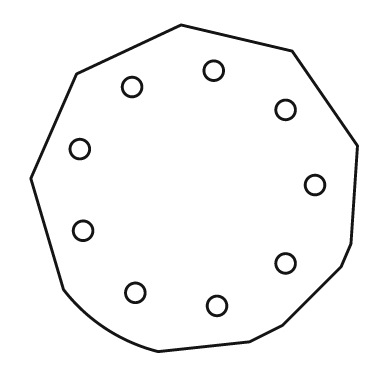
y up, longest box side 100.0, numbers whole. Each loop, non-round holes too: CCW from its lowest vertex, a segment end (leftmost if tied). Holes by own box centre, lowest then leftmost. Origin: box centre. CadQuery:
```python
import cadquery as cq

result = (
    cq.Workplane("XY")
    .moveTo(-11.0, -50.0)
    .lineTo(17.0, -47.0)
    .lineTo(27.0, -42.0)
    .lineTo(45.0, -24.0)
    .lineTo(48.0, -17.0)
    .lineTo(50.0, 13.0)
    .lineTo(30.0, 42.0)
    .lineTo(-4.0, 50.0)
    .lineTo(-36.0, 35.0)
    .lineTo(-50.0, 3.0)
    .lineTo(-40.0, -31.0)
    .threePointArc((-27.0, -43.0), (-11.0, -50.0))
    .close()
    .moveTo(7.0, -36.0)
    .circle(3.0)
    .moveTo(-18.0, -32.0)
    .circle(3.0)
    .moveTo(28.0, -23.0)
    .circle(3.0)
    .moveTo(-34.0, -13.0)
    .circle(3.0)
    .moveTo(37.0, 1.0)
    .circle(3.0)
    .moveTo(-35.0, 12.0)
    .circle(3.0)
    .moveTo(28.0, 24.0)
    .circle(3.0)
    .moveTo(-19.0, 31.0)
    .circle(3.0)
    .moveTo(6.0, 36.0)
    .circle(3.0)
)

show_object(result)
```